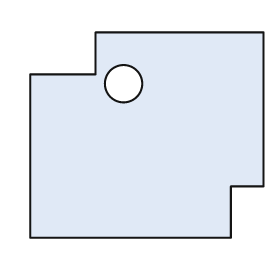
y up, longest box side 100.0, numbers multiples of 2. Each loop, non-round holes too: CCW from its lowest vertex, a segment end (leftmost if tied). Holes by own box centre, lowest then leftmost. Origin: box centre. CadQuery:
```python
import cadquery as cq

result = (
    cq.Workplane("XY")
    .moveTo(-50.0, -44.0)
    .lineTo(36.0, -44.0)
    .lineTo(36.0, -22.0)
    .lineTo(50.0, -22.0)
    .lineTo(50.0, 44.0)
    .lineTo(-22.0, 44.0)
    .lineTo(-22.0, 26.0)
    .lineTo(-50.0, 26.0)
    .close()
    .moveTo(-10.0, 22.0)
    .circle(8.0)
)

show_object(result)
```